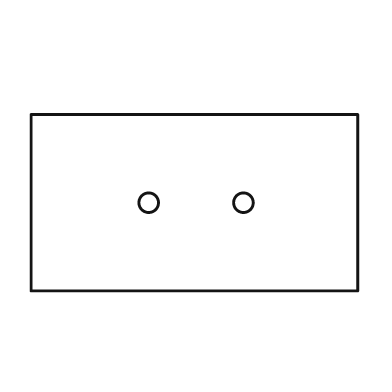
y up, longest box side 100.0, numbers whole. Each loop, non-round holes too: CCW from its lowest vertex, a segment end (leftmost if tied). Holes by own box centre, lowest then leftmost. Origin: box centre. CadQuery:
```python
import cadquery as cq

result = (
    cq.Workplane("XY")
    .moveTo(-50.0, -27.0)
    .lineTo(50.0, -27.0)
    .lineTo(50.0, 27.0)
    .lineTo(-50.0, 27.0)
    .close()
    .moveTo(-14.0, 0.0)
    .circle(3.0)
    .moveTo(15.0, 0.0)
    .circle(3.0)
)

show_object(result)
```